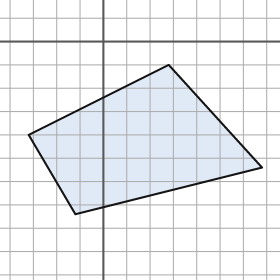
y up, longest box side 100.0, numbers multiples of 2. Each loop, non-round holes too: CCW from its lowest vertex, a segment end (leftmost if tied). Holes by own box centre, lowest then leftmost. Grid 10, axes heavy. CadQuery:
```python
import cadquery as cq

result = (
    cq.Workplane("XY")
    .moveTo(-12.0, -74.0)
    .lineTo(68.0, -54.0)
    .lineTo(28.0, -10.0)
    .lineTo(-32.0, -40.0)
    .close()
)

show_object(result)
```